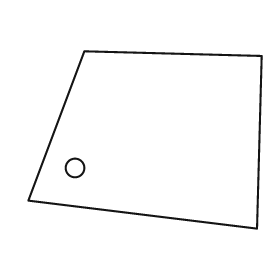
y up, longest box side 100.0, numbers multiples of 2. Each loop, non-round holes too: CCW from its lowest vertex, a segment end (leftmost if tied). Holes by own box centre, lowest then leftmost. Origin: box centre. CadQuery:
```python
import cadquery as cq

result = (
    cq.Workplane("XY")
    .moveTo(48.0, -38.0)
    .lineTo(50.0, 36.0)
    .lineTo(-26.0, 38.0)
    .lineTo(-50.0, -26.0)
    .close()
    .moveTo(-30.0, -12.0)
    .circle(4.0)
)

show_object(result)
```